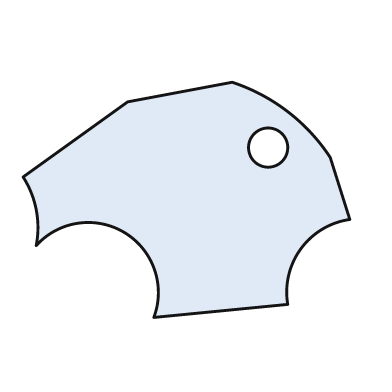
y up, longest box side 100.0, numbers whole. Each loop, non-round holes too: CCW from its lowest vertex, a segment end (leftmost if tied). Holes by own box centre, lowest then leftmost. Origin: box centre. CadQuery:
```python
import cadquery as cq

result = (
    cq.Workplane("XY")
    .moveTo(-10.0, -36.0)
    .lineTo(31.0, -32.0)
    .threePointArc((35.0, -15.0), (50.0, -6.0))
    .lineTo(44.0, 13.0)
    .threePointArc((31.0, 27.0), (14.0, 36.0))
    .lineTo(-18.0, 30.0)
    .lineTo(-50.0, 7.0)
    .threePointArc((-46.0, -3.0), (-46.0, -14.0))
    .threePointArc((-19.0, -10.0), (-10.0, -36.0))
    .close()
    .moveTo(25.0, 16.0)
    .circle(6.0)
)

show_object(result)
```